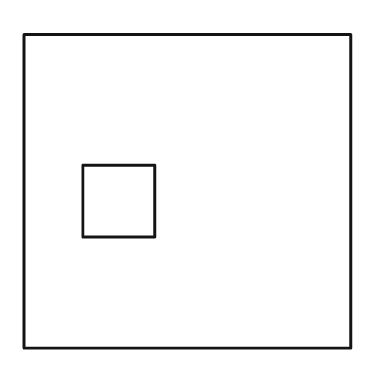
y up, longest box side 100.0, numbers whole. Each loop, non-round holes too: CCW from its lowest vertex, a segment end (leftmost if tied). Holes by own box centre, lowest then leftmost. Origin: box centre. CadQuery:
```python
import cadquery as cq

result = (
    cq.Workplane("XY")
    .moveTo(-50.0, -48.0)
    .lineTo(50.0, -48.0)
    .lineTo(50.0, 48.0)
    .lineTo(-50.0, 48.0)
    .close()
    .moveTo(-32.0, -14.0)
    .lineTo(-10.0, -14.0)
    .lineTo(-10.0, 8.0)
    .lineTo(-32.0, 8.0)
    .close()
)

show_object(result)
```